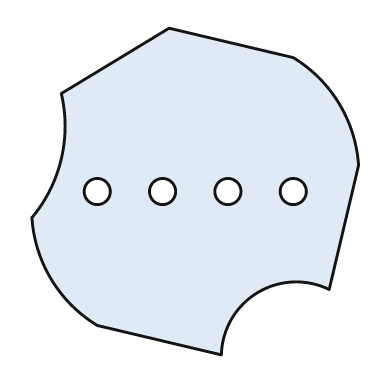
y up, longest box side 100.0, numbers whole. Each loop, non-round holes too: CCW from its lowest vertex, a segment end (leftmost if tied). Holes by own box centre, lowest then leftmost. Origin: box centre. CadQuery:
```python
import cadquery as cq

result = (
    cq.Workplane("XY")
    .moveTo(8.0, -50.0)
    .threePointArc((19.0, -31.0), (41.0, -30.0))
    .lineTo(50.0, 8.0)
    .threePointArc((44.0, 27.0), (30.0, 41.0))
    .lineTo(-8.0, 50.0)
    .lineTo(-41.0, 30.0)
    .threePointArc((-41.0, 10.0), (-50.0, -8.0))
    .threePointArc((-44.0, -27.0), (-30.0, -41.0))
    .close()
    .moveTo(-30.0, 0.0)
    .circle(4.0)
    .moveTo(-10.0, 0.0)
    .circle(4.0)
    .moveTo(10.0, 0.0)
    .circle(4.0)
    .moveTo(30.0, 0.0)
    .circle(4.0)
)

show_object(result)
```